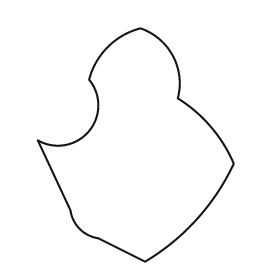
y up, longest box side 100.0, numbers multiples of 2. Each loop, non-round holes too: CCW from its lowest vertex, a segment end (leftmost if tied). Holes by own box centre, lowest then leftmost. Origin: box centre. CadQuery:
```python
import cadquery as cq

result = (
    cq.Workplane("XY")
    .moveTo(4.0, -50.0)
    .threePointArc((26.0, -32.0), (42.0, -8.0))
    .threePointArc((32.0, 8.0), (18.0, 20.0))
    .threePointArc((16.0, 38.0), (2.0, 50.0))
    .threePointArc((-12.0, 42.0), (-20.0, 28.0))
    .threePointArc((-20.0, 6.0), (-42.0, 2.0))
    .lineTo(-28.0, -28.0)
    .threePointArc((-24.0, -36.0), (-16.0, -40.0))
    .close()
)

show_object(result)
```